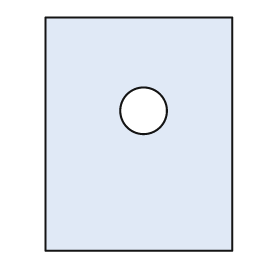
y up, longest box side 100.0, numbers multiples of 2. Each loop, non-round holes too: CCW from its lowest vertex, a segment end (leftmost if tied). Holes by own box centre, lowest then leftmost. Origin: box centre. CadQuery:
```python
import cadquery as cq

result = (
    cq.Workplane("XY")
    .moveTo(-40.0, -50.0)
    .lineTo(40.0, -50.0)
    .lineTo(40.0, 50.0)
    .lineTo(-40.0, 50.0)
    .close()
    .moveTo(2.0, 10.0)
    .circle(10.0)
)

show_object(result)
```